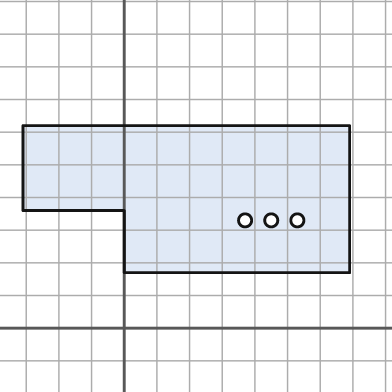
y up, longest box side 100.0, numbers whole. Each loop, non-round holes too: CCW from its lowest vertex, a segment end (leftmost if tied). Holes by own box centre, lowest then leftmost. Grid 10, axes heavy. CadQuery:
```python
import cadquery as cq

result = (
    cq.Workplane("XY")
    .moveTo(0.0, 17.0)
    .lineTo(69.0, 17.0)
    .lineTo(69.0, 62.0)
    .lineTo(-31.0, 62.0)
    .lineTo(-31.0, 36.0)
    .lineTo(0.0, 36.0)
    .close()
    .moveTo(37.0, 33.0)
    .circle(2.0)
    .moveTo(45.0, 33.0)
    .circle(2.0)
    .moveTo(53.0, 33.0)
    .circle(2.0)
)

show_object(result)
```